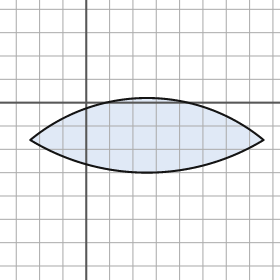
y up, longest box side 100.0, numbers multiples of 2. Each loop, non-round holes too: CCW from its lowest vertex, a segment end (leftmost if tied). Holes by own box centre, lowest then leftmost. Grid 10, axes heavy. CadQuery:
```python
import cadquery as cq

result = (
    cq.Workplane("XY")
    .moveTo(-24.0, -16.0)
    .threePointArc((26.0, -30.0), (76.0, -16.0))
    .threePointArc((26.0, 2.0), (-24.0, -16.0))
    .close()
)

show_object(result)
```